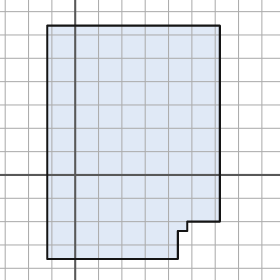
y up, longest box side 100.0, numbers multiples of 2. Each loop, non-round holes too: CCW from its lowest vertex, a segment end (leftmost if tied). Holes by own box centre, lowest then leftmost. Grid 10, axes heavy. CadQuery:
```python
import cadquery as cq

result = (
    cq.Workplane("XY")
    .moveTo(-12.0, -36.0)
    .lineTo(44.0, -36.0)
    .lineTo(44.0, -24.0)
    .lineTo(48.0, -24.0)
    .lineTo(48.0, -20.0)
    .lineTo(62.0, -20.0)
    .lineTo(62.0, 64.0)
    .lineTo(-12.0, 64.0)
    .close()
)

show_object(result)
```